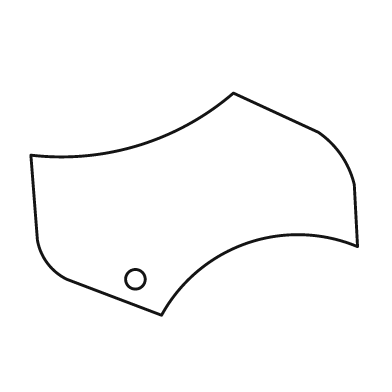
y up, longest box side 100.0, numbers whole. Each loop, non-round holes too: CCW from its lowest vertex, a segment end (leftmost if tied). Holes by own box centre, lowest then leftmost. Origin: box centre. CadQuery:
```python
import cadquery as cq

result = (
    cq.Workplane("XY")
    .moveTo(-10.0, -34.0)
    .threePointArc((16.0, -12.0), (50.0, -13.0))
    .lineTo(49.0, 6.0)
    .threePointArc((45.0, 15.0), (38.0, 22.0))
    .lineTo(12.0, 34.0)
    .threePointArc((-17.0, 18.0), (-50.0, 15.0))
    .lineTo(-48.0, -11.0)
    .threePointArc((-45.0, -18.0), (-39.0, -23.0))
    .close()
    .moveTo(-18.0, -23.0)
    .circle(3.0)
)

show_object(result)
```